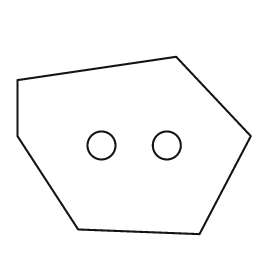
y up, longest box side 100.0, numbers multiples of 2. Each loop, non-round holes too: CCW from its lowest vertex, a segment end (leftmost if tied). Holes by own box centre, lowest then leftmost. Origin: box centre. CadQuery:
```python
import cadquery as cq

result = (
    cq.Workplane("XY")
    .moveTo(28.0, -38.0)
    .lineTo(50.0, 4.0)
    .lineTo(18.0, 38.0)
    .lineTo(-50.0, 28.0)
    .lineTo(-50.0, 4.0)
    .lineTo(-24.0, -36.0)
    .close()
    .moveTo(-14.0, 0.0)
    .circle(6.0)
    .moveTo(14.0, 0.0)
    .circle(6.0)
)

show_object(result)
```